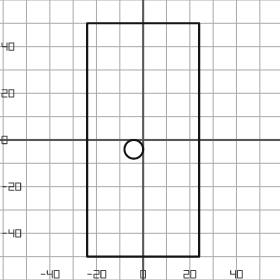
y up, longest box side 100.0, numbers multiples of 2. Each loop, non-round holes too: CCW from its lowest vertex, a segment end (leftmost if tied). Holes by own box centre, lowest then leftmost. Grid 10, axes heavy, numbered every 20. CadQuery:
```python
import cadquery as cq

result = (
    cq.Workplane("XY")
    .moveTo(-24.0, -50.0)
    .lineTo(24.0, -50.0)
    .lineTo(24.0, 50.0)
    .lineTo(-24.0, 50.0)
    .close()
    .moveTo(-4.0, -4.0)
    .circle(4.0)
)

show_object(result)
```